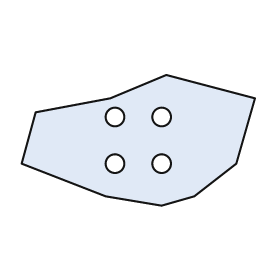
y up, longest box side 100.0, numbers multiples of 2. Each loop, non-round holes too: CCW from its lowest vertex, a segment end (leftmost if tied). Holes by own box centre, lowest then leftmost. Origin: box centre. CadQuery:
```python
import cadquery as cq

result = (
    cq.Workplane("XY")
    .moveTo(10.0, -28.0)
    .lineTo(24.0, -24.0)
    .lineTo(42.0, -10.0)
    .lineTo(50.0, 18.0)
    .lineTo(12.0, 28.0)
    .lineTo(-12.0, 18.0)
    .lineTo(-44.0, 12.0)
    .lineTo(-50.0, -10.0)
    .lineTo(-14.0, -24.0)
    .close()
    .moveTo(-10.0, -10.0)
    .circle(4.0)
    .moveTo(10.0, -10.0)
    .circle(4.0)
    .moveTo(-10.0, 10.0)
    .circle(4.0)
    .moveTo(10.0, 10.0)
    .circle(4.0)
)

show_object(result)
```